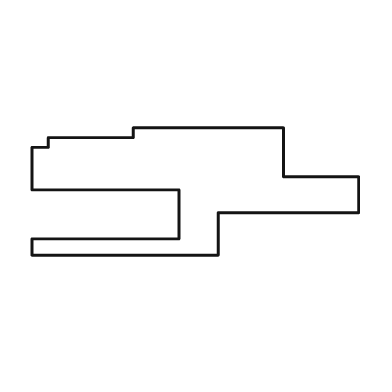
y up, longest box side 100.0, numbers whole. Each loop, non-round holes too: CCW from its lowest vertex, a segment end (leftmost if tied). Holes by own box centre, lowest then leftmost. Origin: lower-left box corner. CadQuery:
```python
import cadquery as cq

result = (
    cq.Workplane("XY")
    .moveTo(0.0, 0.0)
    .lineTo(57.0, 0.0)
    .lineTo(57.0, 13.0)
    .lineTo(100.0, 13.0)
    .lineTo(100.0, 24.0)
    .lineTo(77.0, 24.0)
    .lineTo(77.0, 39.0)
    .lineTo(31.0, 39.0)
    .lineTo(31.0, 36.0)
    .lineTo(5.0, 36.0)
    .lineTo(5.0, 33.0)
    .lineTo(0.0, 33.0)
    .lineTo(0.0, 20.0)
    .lineTo(45.0, 20.0)
    .lineTo(45.0, 5.0)
    .lineTo(0.0, 5.0)
    .close()
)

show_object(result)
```